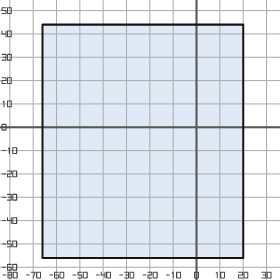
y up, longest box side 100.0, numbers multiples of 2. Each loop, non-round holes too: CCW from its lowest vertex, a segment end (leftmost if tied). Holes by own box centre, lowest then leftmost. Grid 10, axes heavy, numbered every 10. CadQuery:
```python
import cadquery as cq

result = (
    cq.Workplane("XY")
    .moveTo(-66.0, -56.0)
    .lineTo(20.0, -56.0)
    .lineTo(20.0, 44.0)
    .lineTo(-66.0, 44.0)
    .close()
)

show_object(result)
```